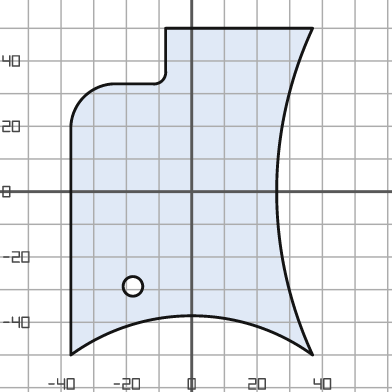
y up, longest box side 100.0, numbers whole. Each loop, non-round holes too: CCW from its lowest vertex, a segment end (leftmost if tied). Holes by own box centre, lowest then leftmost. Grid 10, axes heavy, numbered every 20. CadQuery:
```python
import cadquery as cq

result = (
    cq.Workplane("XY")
    .moveTo(-37.0, -50.0)
    .threePointArc((0.0, -38.0), (37.0, -50.0))
    .threePointArc((26.0, 0.0), (37.0, 50.0))
    .lineTo(-8.0, 50.0)
    .lineTo(-8.0, 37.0)
    .threePointArc((-9.0, 34.0), (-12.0, 33.0))
    .lineTo(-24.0, 33.0)
    .threePointArc((-33.0, 29.0), (-37.0, 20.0))
    .close()
    .moveTo(-18.0, -29.0)
    .circle(3.0)
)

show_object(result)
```